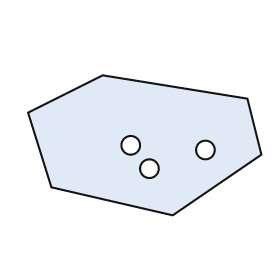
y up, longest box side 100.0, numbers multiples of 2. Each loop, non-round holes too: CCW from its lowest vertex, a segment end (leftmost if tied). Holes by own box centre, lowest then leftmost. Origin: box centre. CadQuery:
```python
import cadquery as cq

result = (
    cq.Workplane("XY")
    .moveTo(12.0, -30.0)
    .lineTo(50.0, -4.0)
    .lineTo(44.0, 20.0)
    .lineTo(-18.0, 30.0)
    .lineTo(-50.0, 14.0)
    .lineTo(-40.0, -18.0)
    .close()
    .moveTo(2.0, -10.0)
    .circle(4.0)
    .moveTo(26.0, -2.0)
    .circle(4.0)
    .moveTo(-6.0, 0.0)
    .circle(4.0)
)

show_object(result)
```